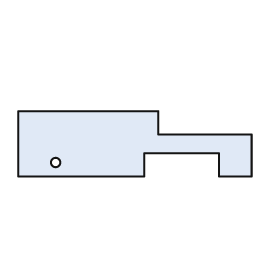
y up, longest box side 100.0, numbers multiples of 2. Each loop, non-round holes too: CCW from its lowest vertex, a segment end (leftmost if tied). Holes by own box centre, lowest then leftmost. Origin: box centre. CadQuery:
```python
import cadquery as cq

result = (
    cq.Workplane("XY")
    .moveTo(-50.0, -14.0)
    .lineTo(4.0, -14.0)
    .lineTo(4.0, -4.0)
    .lineTo(36.0, -4.0)
    .lineTo(36.0, -14.0)
    .lineTo(50.0, -14.0)
    .lineTo(50.0, 4.0)
    .lineTo(10.0, 4.0)
    .lineTo(10.0, 14.0)
    .lineTo(-50.0, 14.0)
    .close()
    .moveTo(-34.0, -8.0)
    .circle(2.0)
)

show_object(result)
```